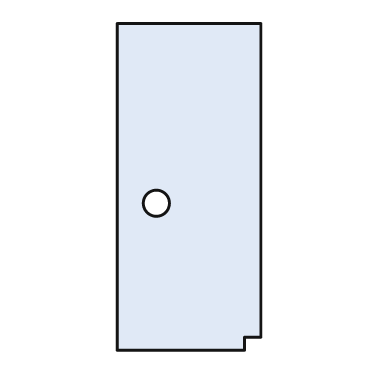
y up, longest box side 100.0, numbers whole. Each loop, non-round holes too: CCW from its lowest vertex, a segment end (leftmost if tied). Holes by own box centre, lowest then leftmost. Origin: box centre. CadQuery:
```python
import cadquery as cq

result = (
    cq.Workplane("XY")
    .moveTo(-22.0, -50.0)
    .lineTo(17.0, -50.0)
    .lineTo(17.0, -46.0)
    .lineTo(22.0, -46.0)
    .lineTo(22.0, 50.0)
    .lineTo(-22.0, 50.0)
    .close()
    .moveTo(-10.0, -5.0)
    .circle(4.0)
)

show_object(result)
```